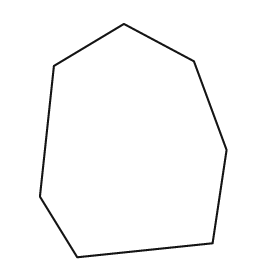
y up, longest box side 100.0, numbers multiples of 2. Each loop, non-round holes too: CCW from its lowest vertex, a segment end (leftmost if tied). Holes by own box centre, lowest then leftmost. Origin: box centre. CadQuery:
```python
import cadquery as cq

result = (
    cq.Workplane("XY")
    .moveTo(-24.0, -50.0)
    .lineTo(34.0, -44.0)
    .lineTo(40.0, -4.0)
    .lineTo(26.0, 34.0)
    .lineTo(-4.0, 50.0)
    .lineTo(-34.0, 32.0)
    .lineTo(-40.0, -24.0)
    .close()
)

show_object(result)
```